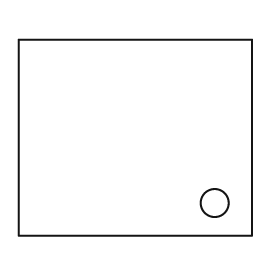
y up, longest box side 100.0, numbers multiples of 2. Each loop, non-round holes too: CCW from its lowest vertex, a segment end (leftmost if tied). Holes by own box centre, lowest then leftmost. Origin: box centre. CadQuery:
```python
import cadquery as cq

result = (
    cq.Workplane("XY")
    .moveTo(-50.0, -42.0)
    .lineTo(50.0, -42.0)
    .lineTo(50.0, 42.0)
    .lineTo(-50.0, 42.0)
    .close()
    .moveTo(34.0, -28.0)
    .circle(6.0)
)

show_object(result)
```